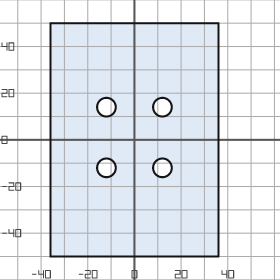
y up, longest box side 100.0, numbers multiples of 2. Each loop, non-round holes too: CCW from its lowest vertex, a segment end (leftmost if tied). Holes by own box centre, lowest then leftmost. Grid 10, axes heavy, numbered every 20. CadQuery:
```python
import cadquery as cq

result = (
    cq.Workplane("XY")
    .moveTo(-36.0, -50.0)
    .lineTo(36.0, -50.0)
    .lineTo(36.0, 50.0)
    .lineTo(-36.0, 50.0)
    .close()
    .moveTo(-12.0, -12.0)
    .circle(4.0)
    .moveTo(12.0, -12.0)
    .circle(4.0)
    .moveTo(-12.0, 14.0)
    .circle(4.0)
    .moveTo(12.0, 14.0)
    .circle(4.0)
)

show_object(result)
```